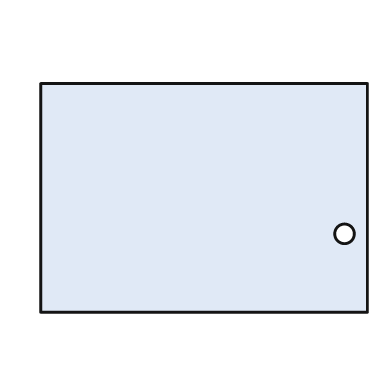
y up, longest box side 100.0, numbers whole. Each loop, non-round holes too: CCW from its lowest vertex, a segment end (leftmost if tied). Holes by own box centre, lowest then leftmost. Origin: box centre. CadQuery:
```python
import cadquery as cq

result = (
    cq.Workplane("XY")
    .moveTo(-50.0, -35.0)
    .lineTo(50.0, -35.0)
    .lineTo(50.0, 35.0)
    .lineTo(-50.0, 35.0)
    .close()
    .moveTo(43.0, -11.0)
    .circle(3.0)
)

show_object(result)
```